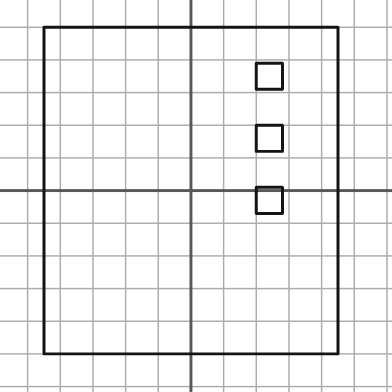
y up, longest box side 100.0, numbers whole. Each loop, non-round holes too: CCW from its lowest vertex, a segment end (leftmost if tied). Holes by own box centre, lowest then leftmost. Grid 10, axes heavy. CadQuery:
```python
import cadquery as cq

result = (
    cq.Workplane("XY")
    .moveTo(-45.0, -50.0)
    .lineTo(45.0, -50.0)
    .lineTo(45.0, 50.0)
    .lineTo(-45.0, 50.0)
    .close()
    .moveTo(20.0, -7.0)
    .lineTo(28.0, -7.0)
    .lineTo(28.0, 1.0)
    .lineTo(20.0, 1.0)
    .close()
    .moveTo(20.0, 12.0)
    .lineTo(28.0, 12.0)
    .lineTo(28.0, 20.0)
    .lineTo(20.0, 20.0)
    .close()
    .moveTo(20.0, 31.0)
    .lineTo(28.0, 31.0)
    .lineTo(28.0, 39.0)
    .lineTo(20.0, 39.0)
    .close()
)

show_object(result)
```